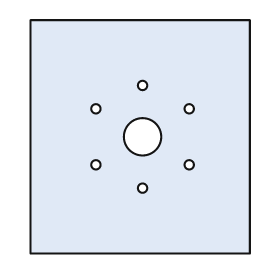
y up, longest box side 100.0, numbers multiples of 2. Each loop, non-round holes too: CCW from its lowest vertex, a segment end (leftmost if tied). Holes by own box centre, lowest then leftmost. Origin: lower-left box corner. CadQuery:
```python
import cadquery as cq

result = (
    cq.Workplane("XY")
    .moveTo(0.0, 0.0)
    .lineTo(94.0, 0.0)
    .lineTo(94.0, 100.0)
    .lineTo(0.0, 100.0)
    .close()
    .moveTo(48.0, 28.0)
    .circle(2.0)
    .moveTo(28.0, 38.0)
    .circle(2.0)
    .moveTo(68.0, 38.0)
    .circle(2.0)
    .moveTo(48.0, 50.0)
    .circle(8.0)
    .moveTo(28.0, 62.0)
    .circle(2.0)
    .moveTo(68.0, 62.0)
    .circle(2.0)
    .moveTo(48.0, 72.0)
    .circle(2.0)
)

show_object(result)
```